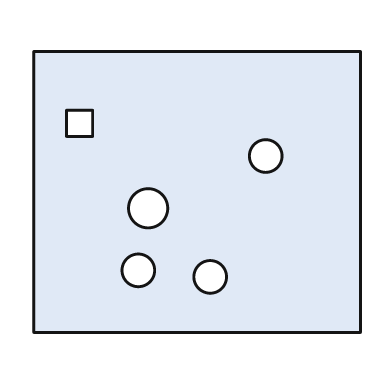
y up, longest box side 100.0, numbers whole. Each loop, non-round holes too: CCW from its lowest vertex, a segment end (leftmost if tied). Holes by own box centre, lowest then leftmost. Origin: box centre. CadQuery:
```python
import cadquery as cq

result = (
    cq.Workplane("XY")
    .moveTo(-50.0, -43.0)
    .lineTo(50.0, -43.0)
    .lineTo(50.0, 43.0)
    .lineTo(-50.0, 43.0)
    .close()
    .moveTo(4.0, -26.0)
    .circle(5.0)
    .moveTo(-18.0, -24.0)
    .circle(5.0)
    .moveTo(-15.0, -5.0)
    .circle(6.0)
    .moveTo(21.0, 11.0)
    .circle(5.0)
    .moveTo(-40.0, 17.0)
    .lineTo(-32.0, 17.0)
    .lineTo(-32.0, 25.0)
    .lineTo(-40.0, 25.0)
    .close()
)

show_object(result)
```